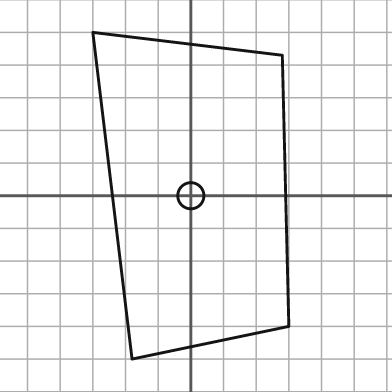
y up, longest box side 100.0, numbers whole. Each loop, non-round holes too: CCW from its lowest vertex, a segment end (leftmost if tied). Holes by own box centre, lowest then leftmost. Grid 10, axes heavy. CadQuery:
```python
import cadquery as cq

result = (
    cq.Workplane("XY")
    .moveTo(-18.0, -50.0)
    .lineTo(30.0, -40.0)
    .lineTo(28.0, 43.0)
    .lineTo(-30.0, 50.0)
    .close()
    .moveTo(0.0, 0.0)
    .circle(4.0)
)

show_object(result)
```